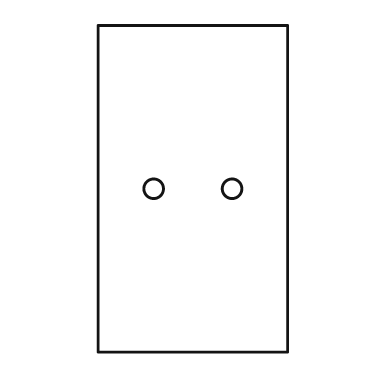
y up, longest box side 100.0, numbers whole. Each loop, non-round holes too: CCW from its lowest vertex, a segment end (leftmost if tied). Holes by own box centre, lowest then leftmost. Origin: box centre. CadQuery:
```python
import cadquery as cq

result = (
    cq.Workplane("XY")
    .moveTo(-29.0, -50.0)
    .lineTo(29.0, -50.0)
    .lineTo(29.0, 50.0)
    .lineTo(-29.0, 50.0)
    .close()
    .moveTo(-12.0, 0.0)
    .circle(3.0)
    .moveTo(12.0, 0.0)
    .circle(3.0)
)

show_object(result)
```